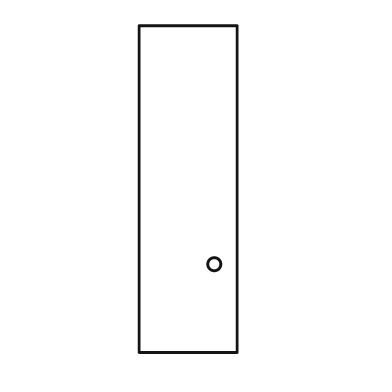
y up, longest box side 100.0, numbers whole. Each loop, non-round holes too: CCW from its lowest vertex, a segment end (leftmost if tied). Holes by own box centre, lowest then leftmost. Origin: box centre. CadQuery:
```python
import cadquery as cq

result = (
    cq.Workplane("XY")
    .moveTo(-15.0, -50.0)
    .lineTo(15.0, -50.0)
    .lineTo(15.0, 50.0)
    .lineTo(-15.0, 50.0)
    .close()
    .moveTo(8.0, -23.0)
    .circle(2.0)
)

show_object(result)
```